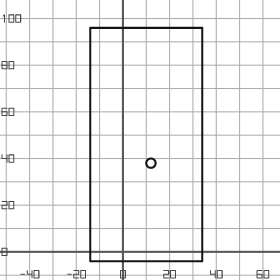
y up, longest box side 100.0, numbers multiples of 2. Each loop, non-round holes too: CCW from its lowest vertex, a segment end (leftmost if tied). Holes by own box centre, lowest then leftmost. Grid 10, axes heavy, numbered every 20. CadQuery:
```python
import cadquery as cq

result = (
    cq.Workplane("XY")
    .moveTo(-14.0, -4.0)
    .lineTo(34.0, -4.0)
    .lineTo(34.0, 96.0)
    .lineTo(-14.0, 96.0)
    .close()
    .moveTo(12.0, 38.0)
    .circle(2.0)
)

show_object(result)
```